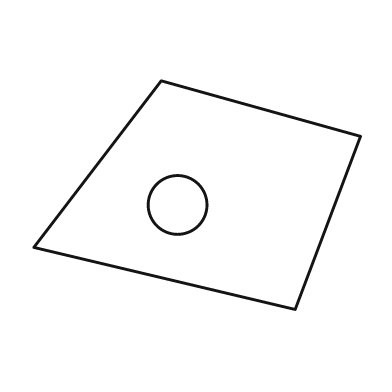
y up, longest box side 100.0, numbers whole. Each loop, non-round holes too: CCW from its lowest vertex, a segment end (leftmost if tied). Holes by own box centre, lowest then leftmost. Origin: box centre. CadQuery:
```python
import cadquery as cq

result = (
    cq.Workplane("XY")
    .moveTo(30.0, -35.0)
    .lineTo(50.0, 18.0)
    .lineTo(-11.0, 35.0)
    .lineTo(-50.0, -16.0)
    .close()
    .moveTo(-6.0, -3.0)
    .circle(9.0)
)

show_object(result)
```